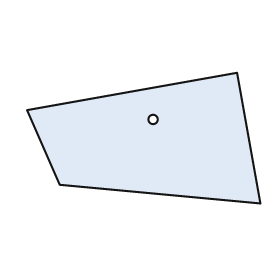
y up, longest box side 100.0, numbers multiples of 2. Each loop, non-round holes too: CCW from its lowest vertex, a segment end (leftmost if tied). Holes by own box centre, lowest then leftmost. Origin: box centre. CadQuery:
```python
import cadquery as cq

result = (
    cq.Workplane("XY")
    .moveTo(50.0, -28.0)
    .lineTo(40.0, 28.0)
    .lineTo(-50.0, 12.0)
    .lineTo(-36.0, -20.0)
    .close()
    .moveTo(4.0, 8.0)
    .circle(2.0)
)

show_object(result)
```